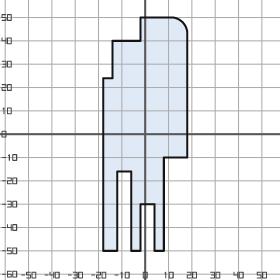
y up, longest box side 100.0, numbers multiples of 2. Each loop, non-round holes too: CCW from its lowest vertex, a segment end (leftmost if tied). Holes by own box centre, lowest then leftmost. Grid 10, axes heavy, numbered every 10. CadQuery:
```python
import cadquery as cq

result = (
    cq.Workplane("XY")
    .moveTo(-18.0, -50.0)
    .lineTo(-12.0, -50.0)
    .lineTo(-12.0, -16.0)
    .lineTo(-6.0, -16.0)
    .lineTo(-6.0, -50.0)
    .lineTo(-2.0, -50.0)
    .lineTo(-2.0, -30.0)
    .lineTo(4.0, -30.0)
    .lineTo(4.0, -50.0)
    .lineTo(8.0, -50.0)
    .lineTo(8.0, -10.0)
    .lineTo(18.0, -10.0)
    .lineTo(18.0, 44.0)
    .threePointArc((16.0, 48.0), (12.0, 50.0))
    .lineTo(-2.0, 50.0)
    .lineTo(-2.0, 40.0)
    .lineTo(-14.0, 40.0)
    .lineTo(-14.0, 24.0)
    .lineTo(-18.0, 24.0)
    .close()
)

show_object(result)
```